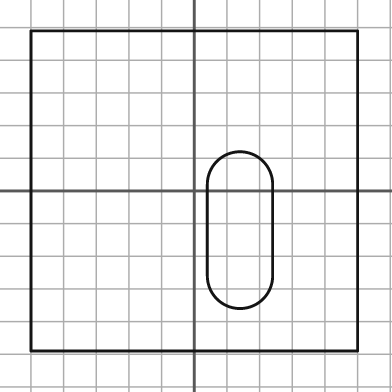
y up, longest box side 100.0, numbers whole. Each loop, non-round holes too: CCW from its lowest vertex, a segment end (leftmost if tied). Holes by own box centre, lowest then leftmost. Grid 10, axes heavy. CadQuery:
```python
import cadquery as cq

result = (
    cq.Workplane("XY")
    .moveTo(-50.0, -49.0)
    .lineTo(50.0, -49.0)
    .lineTo(50.0, 49.0)
    .lineTo(-50.0, 49.0)
    .close()
    .moveTo(4.0, -26.0)
    .threePointArc((14.0, -36.0), (24.0, -26.0))
    .lineTo(24.0, 2.0)
    .threePointArc((14.0, 12.0), (4.0, 2.0))
    .close()
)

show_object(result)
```